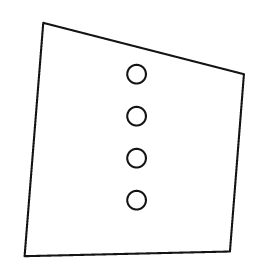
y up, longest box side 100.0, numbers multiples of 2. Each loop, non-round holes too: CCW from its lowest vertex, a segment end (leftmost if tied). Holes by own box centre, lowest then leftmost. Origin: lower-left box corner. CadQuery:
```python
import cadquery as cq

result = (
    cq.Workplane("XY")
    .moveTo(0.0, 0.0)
    .lineTo(88.0, 2.0)
    .lineTo(94.0, 78.0)
    .lineTo(8.0, 100.0)
    .close()
    .moveTo(48.0, 24.0)
    .circle(4.0)
    .moveTo(48.0, 42.0)
    .circle(4.0)
    .moveTo(48.0, 60.0)
    .circle(4.0)
    .moveTo(48.0, 78.0)
    .circle(4.0)
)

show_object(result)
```